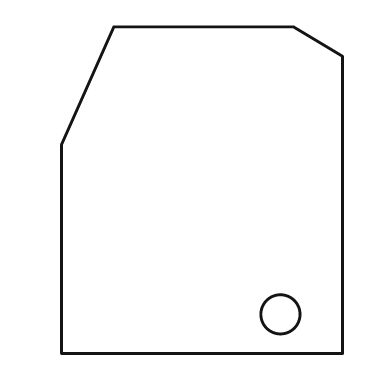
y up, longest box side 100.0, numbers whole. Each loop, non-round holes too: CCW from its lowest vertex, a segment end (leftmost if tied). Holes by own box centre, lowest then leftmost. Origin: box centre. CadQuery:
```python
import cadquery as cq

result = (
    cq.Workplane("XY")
    .moveTo(-43.0, -50.0)
    .lineTo(43.0, -50.0)
    .lineTo(43.0, 41.0)
    .lineTo(28.0, 50.0)
    .lineTo(-27.0, 50.0)
    .lineTo(-43.0, 14.0)
    .close()
    .moveTo(24.0, -38.0)
    .circle(6.0)
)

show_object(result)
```